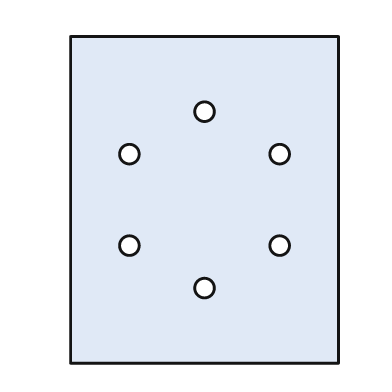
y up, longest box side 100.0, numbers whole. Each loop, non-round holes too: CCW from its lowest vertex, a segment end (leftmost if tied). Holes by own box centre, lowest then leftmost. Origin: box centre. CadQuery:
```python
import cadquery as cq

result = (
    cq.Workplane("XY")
    .moveTo(-41.0, -50.0)
    .lineTo(41.0, -50.0)
    .lineTo(41.0, 50.0)
    .lineTo(-41.0, 50.0)
    .close()
    .moveTo(0.0, -27.0)
    .circle(3.0)
    .moveTo(-23.0, -14.0)
    .circle(3.0)
    .moveTo(23.0, -14.0)
    .circle(3.0)
    .moveTo(-23.0, 14.0)
    .circle(3.0)
    .moveTo(23.0, 14.0)
    .circle(3.0)
    .moveTo(0.0, 27.0)
    .circle(3.0)
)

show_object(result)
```